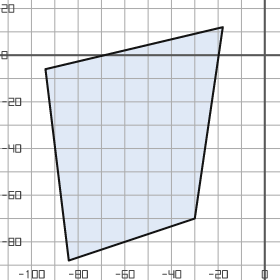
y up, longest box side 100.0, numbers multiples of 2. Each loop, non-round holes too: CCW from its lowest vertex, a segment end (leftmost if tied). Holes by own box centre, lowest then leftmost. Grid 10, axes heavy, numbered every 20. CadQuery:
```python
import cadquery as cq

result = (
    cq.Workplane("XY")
    .moveTo(-84.0, -88.0)
    .lineTo(-30.0, -70.0)
    .lineTo(-18.0, 12.0)
    .lineTo(-94.0, -6.0)
    .close()
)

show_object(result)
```